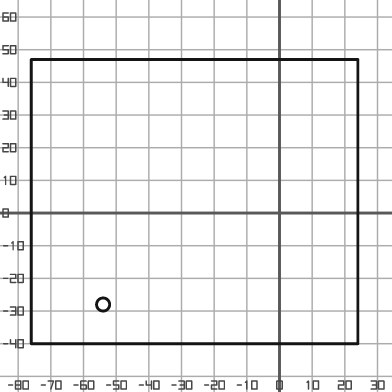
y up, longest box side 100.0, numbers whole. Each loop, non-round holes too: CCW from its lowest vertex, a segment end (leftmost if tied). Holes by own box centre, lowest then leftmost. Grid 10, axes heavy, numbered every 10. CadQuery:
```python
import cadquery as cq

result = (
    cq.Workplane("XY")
    .moveTo(-76.0, -40.0)
    .lineTo(24.0, -40.0)
    .lineTo(24.0, 47.0)
    .lineTo(-76.0, 47.0)
    .close()
    .moveTo(-54.0, -28.0)
    .circle(2.0)
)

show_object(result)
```